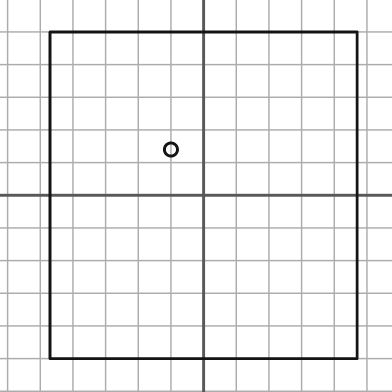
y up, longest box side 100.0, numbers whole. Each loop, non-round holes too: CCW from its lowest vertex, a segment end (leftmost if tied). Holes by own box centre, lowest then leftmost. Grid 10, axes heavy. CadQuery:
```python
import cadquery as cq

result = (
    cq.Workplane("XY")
    .moveTo(-47.0, -50.0)
    .lineTo(47.0, -50.0)
    .lineTo(47.0, 50.0)
    .lineTo(-47.0, 50.0)
    .close()
    .moveTo(-10.0, 14.0)
    .circle(2.0)
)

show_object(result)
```